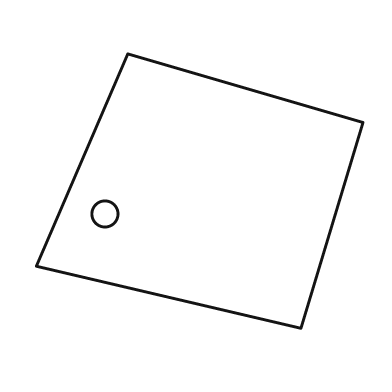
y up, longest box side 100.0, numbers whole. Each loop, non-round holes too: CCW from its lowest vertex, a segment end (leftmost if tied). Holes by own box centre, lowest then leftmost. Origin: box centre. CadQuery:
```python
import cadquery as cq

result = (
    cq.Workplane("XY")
    .moveTo(31.0, -42.0)
    .lineTo(50.0, 21.0)
    .lineTo(-22.0, 42.0)
    .lineTo(-50.0, -23.0)
    .close()
    .moveTo(-29.0, -7.0)
    .circle(4.0)
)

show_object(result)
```